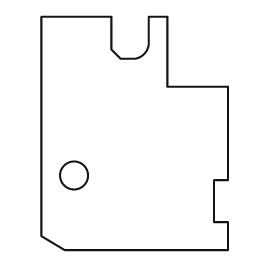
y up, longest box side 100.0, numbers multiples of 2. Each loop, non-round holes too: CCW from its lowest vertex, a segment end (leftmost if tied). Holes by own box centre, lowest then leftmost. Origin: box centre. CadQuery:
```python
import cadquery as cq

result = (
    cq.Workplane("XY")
    .moveTo(-30.0, -50.0)
    .lineTo(40.0, -50.0)
    .lineTo(40.0, -38.0)
    .lineTo(34.0, -38.0)
    .lineTo(34.0, -20.0)
    .lineTo(40.0, -20.0)
    .lineTo(40.0, 20.0)
    .lineTo(14.0, 20.0)
    .lineTo(14.0, 50.0)
    .lineTo(6.0, 50.0)
    .lineTo(6.0, 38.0)
    .threePointArc((4.0, 34.0), (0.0, 32.0))
    .lineTo(-6.0, 32.0)
    .lineTo(-10.0, 36.0)
    .lineTo(-10.0, 50.0)
    .lineTo(-40.0, 50.0)
    .lineTo(-40.0, -44.0)
    .close()
    .moveTo(-26.0, -18.0)
    .circle(6.0)
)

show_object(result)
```